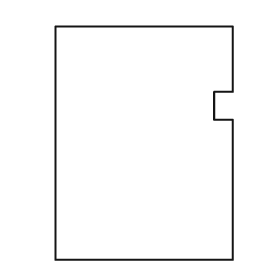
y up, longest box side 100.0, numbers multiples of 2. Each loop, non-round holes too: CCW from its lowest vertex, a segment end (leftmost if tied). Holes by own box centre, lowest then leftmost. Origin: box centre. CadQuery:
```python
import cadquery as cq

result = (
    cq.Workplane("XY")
    .moveTo(-38.0, -50.0)
    .lineTo(38.0, -50.0)
    .lineTo(38.0, 10.0)
    .lineTo(30.0, 10.0)
    .lineTo(30.0, 22.0)
    .lineTo(38.0, 22.0)
    .lineTo(38.0, 50.0)
    .lineTo(-38.0, 50.0)
    .close()
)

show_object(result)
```